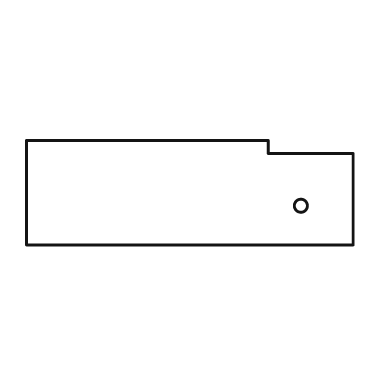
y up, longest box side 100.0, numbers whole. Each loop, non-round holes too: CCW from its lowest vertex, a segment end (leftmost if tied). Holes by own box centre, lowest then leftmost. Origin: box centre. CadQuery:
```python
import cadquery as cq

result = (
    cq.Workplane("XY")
    .moveTo(-50.0, -16.0)
    .lineTo(50.0, -16.0)
    .lineTo(50.0, 12.0)
    .lineTo(24.0, 12.0)
    .lineTo(24.0, 16.0)
    .lineTo(-50.0, 16.0)
    .close()
    .moveTo(34.0, -4.0)
    .circle(2.0)
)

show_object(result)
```